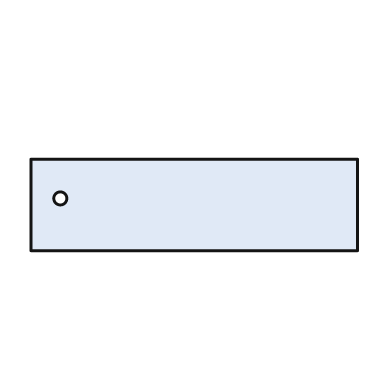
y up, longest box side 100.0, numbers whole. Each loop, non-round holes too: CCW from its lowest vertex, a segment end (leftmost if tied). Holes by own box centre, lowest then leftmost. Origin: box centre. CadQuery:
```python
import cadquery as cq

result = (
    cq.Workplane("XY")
    .moveTo(-50.0, -14.0)
    .lineTo(50.0, -14.0)
    .lineTo(50.0, 14.0)
    .lineTo(-50.0, 14.0)
    .close()
    .moveTo(-41.0, 2.0)
    .circle(2.0)
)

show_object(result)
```